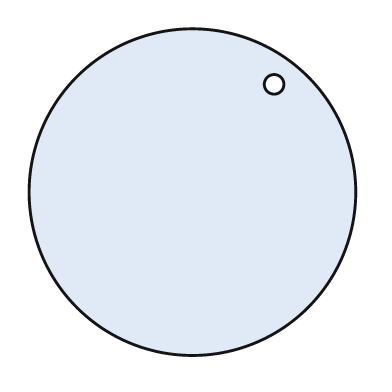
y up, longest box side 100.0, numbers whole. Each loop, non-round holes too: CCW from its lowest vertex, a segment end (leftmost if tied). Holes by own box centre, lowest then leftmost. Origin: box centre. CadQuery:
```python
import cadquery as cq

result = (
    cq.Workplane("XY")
    .moveTo(0.0, 0.0)
    .circle(50.0)
    .moveTo(25.0, 33.0)
    .circle(3.0)
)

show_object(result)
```